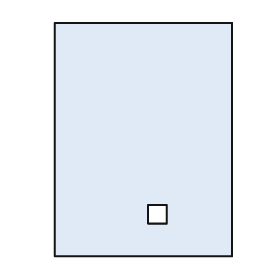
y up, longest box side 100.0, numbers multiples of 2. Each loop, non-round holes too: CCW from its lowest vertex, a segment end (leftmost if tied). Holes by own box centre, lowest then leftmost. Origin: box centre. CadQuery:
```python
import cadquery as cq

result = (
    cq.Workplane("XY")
    .moveTo(-38.0, -50.0)
    .lineTo(38.0, -50.0)
    .lineTo(38.0, 50.0)
    .lineTo(-38.0, 50.0)
    .close()
    .moveTo(2.0, -36.0)
    .lineTo(10.0, -36.0)
    .lineTo(10.0, -28.0)
    .lineTo(2.0, -28.0)
    .close()
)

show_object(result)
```